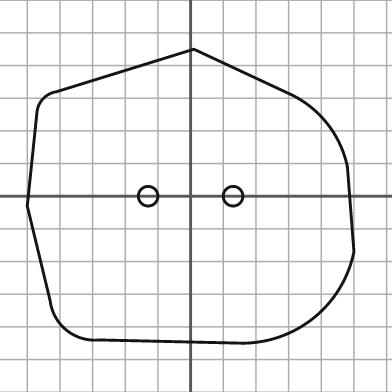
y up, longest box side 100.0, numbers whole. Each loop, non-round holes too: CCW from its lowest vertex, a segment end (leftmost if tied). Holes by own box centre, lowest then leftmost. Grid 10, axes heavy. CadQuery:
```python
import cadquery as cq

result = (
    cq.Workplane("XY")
    .moveTo(16.0, -45.0)
    .threePointArc((38.0, -37.0), (50.0, -17.0))
    .lineTo(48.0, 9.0)
    .threePointArc((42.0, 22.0), (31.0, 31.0))
    .lineTo(1.0, 45.0)
    .lineTo(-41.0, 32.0)
    .threePointArc((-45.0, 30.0), (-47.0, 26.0))
    .lineTo(-50.0, -3.0)
    .lineTo(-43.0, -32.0)
    .threePointArc((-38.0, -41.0), (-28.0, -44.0))
    .close()
    .moveTo(-13.0, 0.0)
    .circle(3.0)
    .moveTo(13.0, 0.0)
    .circle(3.0)
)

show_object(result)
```